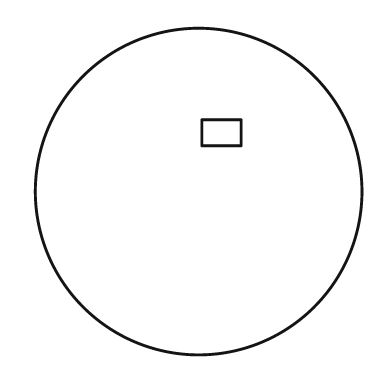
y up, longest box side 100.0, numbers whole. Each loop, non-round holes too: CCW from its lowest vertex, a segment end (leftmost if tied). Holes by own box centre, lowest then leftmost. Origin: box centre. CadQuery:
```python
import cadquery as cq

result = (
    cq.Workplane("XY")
    .moveTo(0.0, 0.0)
    .circle(50.0)
    .moveTo(1.0, 14.0)
    .lineTo(13.0, 14.0)
    .lineTo(13.0, 22.0)
    .lineTo(1.0, 22.0)
    .close()
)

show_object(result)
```